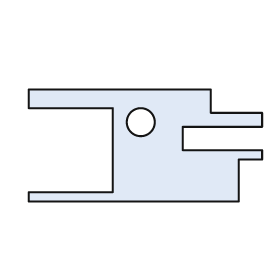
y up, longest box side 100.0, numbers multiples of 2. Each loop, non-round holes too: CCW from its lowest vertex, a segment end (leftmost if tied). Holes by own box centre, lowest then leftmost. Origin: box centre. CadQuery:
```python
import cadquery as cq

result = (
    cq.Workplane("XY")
    .moveTo(-50.0, -24.0)
    .lineTo(40.0, -24.0)
    .lineTo(40.0, -6.0)
    .lineTo(50.0, -6.0)
    .lineTo(50.0, -2.0)
    .lineTo(16.0, -2.0)
    .lineTo(16.0, 8.0)
    .lineTo(50.0, 8.0)
    .lineTo(50.0, 14.0)
    .lineTo(28.0, 14.0)
    .lineTo(28.0, 24.0)
    .lineTo(-50.0, 24.0)
    .lineTo(-50.0, 16.0)
    .lineTo(-14.0, 16.0)
    .lineTo(-14.0, -20.0)
    .lineTo(-50.0, -20.0)
    .close()
    .moveTo(-2.0, 10.0)
    .circle(6.0)
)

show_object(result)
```